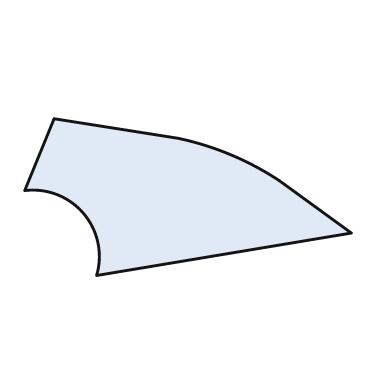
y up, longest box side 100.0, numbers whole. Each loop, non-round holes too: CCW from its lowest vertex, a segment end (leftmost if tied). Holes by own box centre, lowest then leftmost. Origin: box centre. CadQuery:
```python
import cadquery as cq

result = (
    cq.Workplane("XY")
    .moveTo(-28.0, -24.0)
    .lineTo(50.0, -11.0)
    .lineTo(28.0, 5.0)
    .threePointArc((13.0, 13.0), (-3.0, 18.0))
    .lineTo(-41.0, 24.0)
    .lineTo(-50.0, 2.0)
    .threePointArc((-32.0, -5.0), (-28.0, -24.0))
    .close()
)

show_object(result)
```